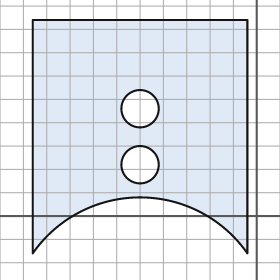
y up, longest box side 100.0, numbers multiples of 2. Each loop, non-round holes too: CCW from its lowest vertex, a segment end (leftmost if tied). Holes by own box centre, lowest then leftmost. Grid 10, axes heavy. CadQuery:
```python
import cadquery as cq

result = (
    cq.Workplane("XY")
    .moveTo(-96.0, -16.0)
    .threePointArc((-50.0, 8.0), (-4.0, -16.0))
    .lineTo(-4.0, 84.0)
    .lineTo(-96.0, 84.0)
    .close()
    .moveTo(-50.0, 22.0)
    .circle(8.0)
    .moveTo(-50.0, 46.0)
    .circle(8.0)
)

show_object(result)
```